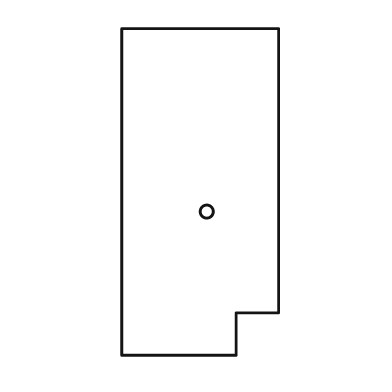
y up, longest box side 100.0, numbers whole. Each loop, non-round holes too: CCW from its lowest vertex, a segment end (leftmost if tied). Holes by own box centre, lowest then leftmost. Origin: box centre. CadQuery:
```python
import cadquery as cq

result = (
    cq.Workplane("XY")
    .moveTo(-24.0, -50.0)
    .lineTo(11.0, -50.0)
    .lineTo(11.0, -37.0)
    .lineTo(24.0, -37.0)
    .lineTo(24.0, 50.0)
    .lineTo(-24.0, 50.0)
    .close()
    .moveTo(2.0, -6.0)
    .circle(2.0)
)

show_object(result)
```